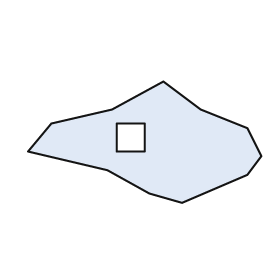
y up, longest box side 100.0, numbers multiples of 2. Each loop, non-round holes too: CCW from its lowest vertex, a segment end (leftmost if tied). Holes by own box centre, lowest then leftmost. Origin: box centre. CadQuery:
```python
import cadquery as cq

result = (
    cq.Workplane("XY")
    .moveTo(16.0, -26.0)
    .lineTo(44.0, -14.0)
    .lineTo(50.0, -6.0)
    .lineTo(44.0, 6.0)
    .lineTo(24.0, 14.0)
    .lineTo(8.0, 26.0)
    .lineTo(-14.0, 14.0)
    .lineTo(-40.0, 8.0)
    .lineTo(-50.0, -4.0)
    .lineTo(-16.0, -12.0)
    .lineTo(2.0, -22.0)
    .close()
    .moveTo(-12.0, -4.0)
    .lineTo(0.0, -4.0)
    .lineTo(0.0, 8.0)
    .lineTo(-12.0, 8.0)
    .close()
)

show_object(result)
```